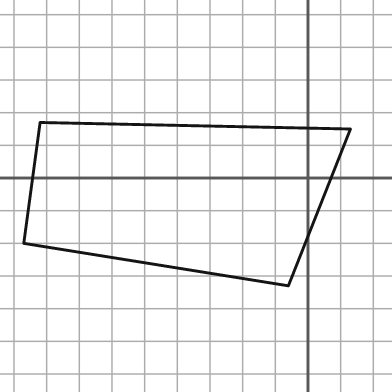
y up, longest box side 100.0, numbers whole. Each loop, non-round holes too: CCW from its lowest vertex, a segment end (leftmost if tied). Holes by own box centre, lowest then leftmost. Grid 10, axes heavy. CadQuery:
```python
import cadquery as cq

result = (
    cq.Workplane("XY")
    .moveTo(-6.0, -33.0)
    .lineTo(13.0, 15.0)
    .lineTo(-82.0, 17.0)
    .lineTo(-87.0, -20.0)
    .close()
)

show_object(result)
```